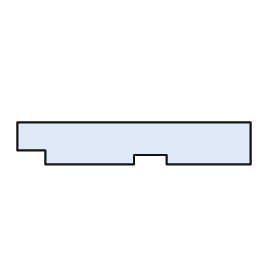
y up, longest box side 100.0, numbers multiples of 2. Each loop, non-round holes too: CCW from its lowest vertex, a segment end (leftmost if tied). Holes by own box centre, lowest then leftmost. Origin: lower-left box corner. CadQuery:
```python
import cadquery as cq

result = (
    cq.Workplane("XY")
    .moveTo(12.0, 0.0)
    .lineTo(50.0, 0.0)
    .lineTo(50.0, 4.0)
    .lineTo(64.0, 4.0)
    .lineTo(64.0, 0.0)
    .lineTo(100.0, 0.0)
    .lineTo(100.0, 18.0)
    .lineTo(0.0, 18.0)
    .lineTo(0.0, 6.0)
    .lineTo(12.0, 6.0)
    .close()
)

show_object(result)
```